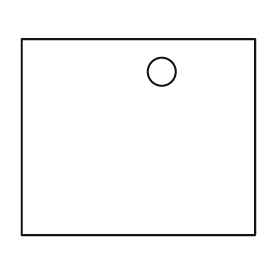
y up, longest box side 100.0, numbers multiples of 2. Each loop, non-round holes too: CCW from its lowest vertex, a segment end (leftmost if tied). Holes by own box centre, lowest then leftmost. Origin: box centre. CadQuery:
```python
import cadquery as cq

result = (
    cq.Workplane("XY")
    .moveTo(-50.0, -42.0)
    .lineTo(50.0, -42.0)
    .lineTo(50.0, 42.0)
    .lineTo(-50.0, 42.0)
    .close()
    .moveTo(10.0, 28.0)
    .circle(6.0)
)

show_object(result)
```